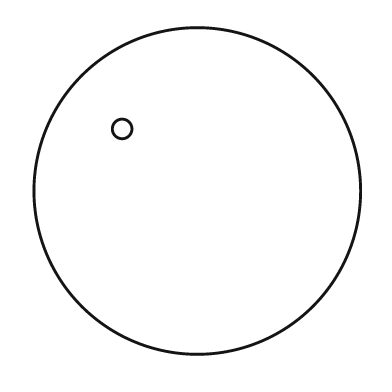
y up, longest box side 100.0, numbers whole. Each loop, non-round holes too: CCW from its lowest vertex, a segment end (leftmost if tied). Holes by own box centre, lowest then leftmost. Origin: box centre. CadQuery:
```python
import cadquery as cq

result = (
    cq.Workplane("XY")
    .moveTo(0.0, 0.0)
    .circle(50.0)
    .moveTo(-23.0, 19.0)
    .circle(3.0)
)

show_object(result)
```